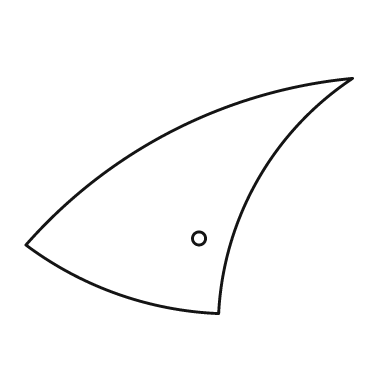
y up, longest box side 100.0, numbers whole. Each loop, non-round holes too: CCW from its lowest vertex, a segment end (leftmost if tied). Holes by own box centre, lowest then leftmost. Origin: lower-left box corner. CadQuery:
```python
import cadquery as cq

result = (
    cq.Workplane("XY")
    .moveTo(59.0, 0.0)
    .threePointArc((71.0, 41.0), (100.0, 72.0))
    .threePointArc((45.0, 56.0), (0.0, 21.0))
    .threePointArc((28.0, 6.0), (59.0, 0.0))
    .close()
    .moveTo(53.0, 23.0)
    .circle(2.0)
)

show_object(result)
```